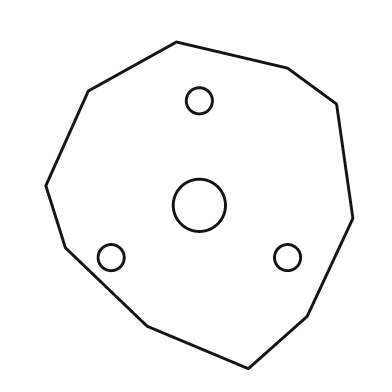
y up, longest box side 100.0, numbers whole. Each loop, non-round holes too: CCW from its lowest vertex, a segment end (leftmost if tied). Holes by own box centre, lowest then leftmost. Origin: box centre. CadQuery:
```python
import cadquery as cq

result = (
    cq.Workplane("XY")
    .moveTo(15.0, -50.0)
    .lineTo(33.0, -34.0)
    .lineTo(47.0, -4.0)
    .lineTo(42.0, 31.0)
    .lineTo(27.0, 42.0)
    .lineTo(-7.0, 50.0)
    .lineTo(-34.0, 35.0)
    .lineTo(-47.0, 6.0)
    .lineTo(-41.0, -13.0)
    .lineTo(-16.0, -37.0)
    .close()
    .moveTo(-27.0, -16.0)
    .circle(4.0)
    .moveTo(27.0, -16.0)
    .circle(4.0)
    .moveTo(0.0, 0.0)
    .circle(8.0)
    .moveTo(0.0, 32.0)
    .circle(4.0)
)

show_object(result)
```